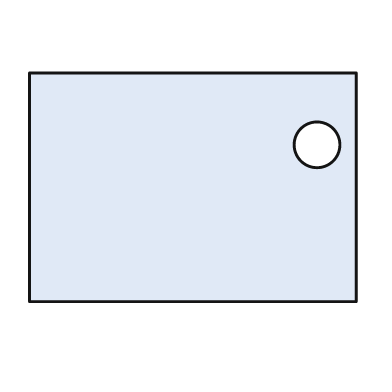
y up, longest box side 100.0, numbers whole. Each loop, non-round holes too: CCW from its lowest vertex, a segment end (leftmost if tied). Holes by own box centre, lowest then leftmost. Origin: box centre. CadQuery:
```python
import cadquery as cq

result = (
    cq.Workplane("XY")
    .moveTo(-50.0, -35.0)
    .lineTo(50.0, -35.0)
    .lineTo(50.0, 35.0)
    .lineTo(-50.0, 35.0)
    .close()
    .moveTo(38.0, 13.0)
    .circle(7.0)
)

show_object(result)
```